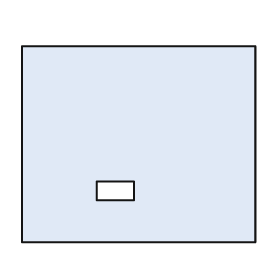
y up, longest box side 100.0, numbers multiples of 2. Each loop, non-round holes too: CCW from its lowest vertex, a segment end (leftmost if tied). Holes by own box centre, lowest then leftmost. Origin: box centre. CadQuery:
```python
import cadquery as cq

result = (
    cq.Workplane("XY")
    .moveTo(-50.0, -42.0)
    .lineTo(50.0, -42.0)
    .lineTo(50.0, 42.0)
    .lineTo(-50.0, 42.0)
    .close()
    .moveTo(-18.0, -24.0)
    .lineTo(-2.0, -24.0)
    .lineTo(-2.0, -16.0)
    .lineTo(-18.0, -16.0)
    .close()
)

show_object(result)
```